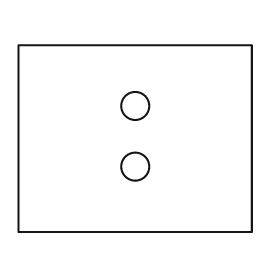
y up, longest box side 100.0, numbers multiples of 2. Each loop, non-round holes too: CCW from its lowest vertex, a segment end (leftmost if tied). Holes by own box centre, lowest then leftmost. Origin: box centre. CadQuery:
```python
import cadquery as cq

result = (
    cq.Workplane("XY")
    .moveTo(-50.0, -40.0)
    .lineTo(50.0, -40.0)
    .lineTo(50.0, 40.0)
    .lineTo(-50.0, 40.0)
    .close()
    .moveTo(0.0, -12.0)
    .circle(6.0)
    .moveTo(0.0, 14.0)
    .circle(6.0)
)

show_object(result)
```